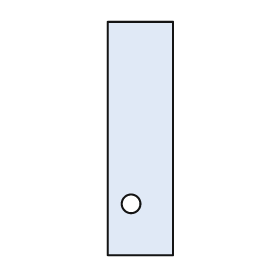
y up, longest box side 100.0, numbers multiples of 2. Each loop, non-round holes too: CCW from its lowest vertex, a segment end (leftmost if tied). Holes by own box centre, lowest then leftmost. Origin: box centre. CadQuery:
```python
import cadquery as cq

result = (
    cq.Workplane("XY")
    .moveTo(-14.0, -50.0)
    .lineTo(14.0, -50.0)
    .lineTo(14.0, 50.0)
    .lineTo(-14.0, 50.0)
    .close()
    .moveTo(-4.0, -28.0)
    .circle(4.0)
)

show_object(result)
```